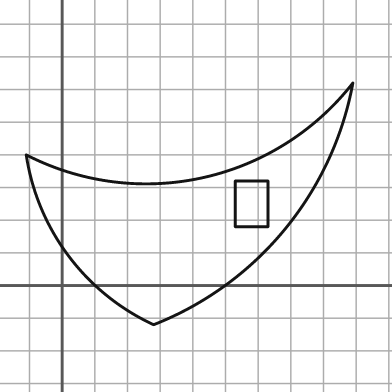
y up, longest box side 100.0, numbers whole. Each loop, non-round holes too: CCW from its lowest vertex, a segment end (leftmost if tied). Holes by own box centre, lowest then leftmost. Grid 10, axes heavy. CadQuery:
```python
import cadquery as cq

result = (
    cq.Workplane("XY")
    .moveTo(28.0, -12.0)
    .threePointArc((68.0, 17.0), (89.0, 62.0))
    .threePointArc((43.0, 33.0), (-11.0, 40.0))
    .threePointArc((2.0, 9.0), (28.0, -12.0))
    .close()
    .moveTo(53.0, 18.0)
    .lineTo(63.0, 18.0)
    .lineTo(63.0, 32.0)
    .lineTo(53.0, 32.0)
    .close()
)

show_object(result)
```